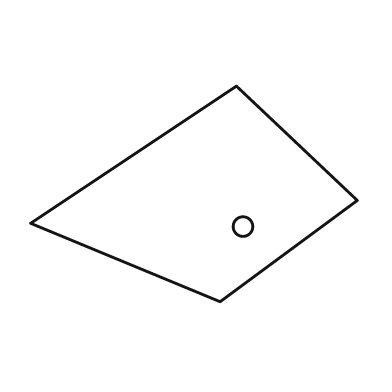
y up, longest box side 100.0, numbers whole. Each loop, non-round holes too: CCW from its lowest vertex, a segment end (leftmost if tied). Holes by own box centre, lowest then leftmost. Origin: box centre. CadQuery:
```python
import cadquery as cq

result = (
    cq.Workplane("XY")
    .moveTo(8.0, -33.0)
    .lineTo(50.0, -2.0)
    .lineTo(13.0, 33.0)
    .lineTo(-50.0, -9.0)
    .close()
    .moveTo(15.0, -10.0)
    .circle(3.0)
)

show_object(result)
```